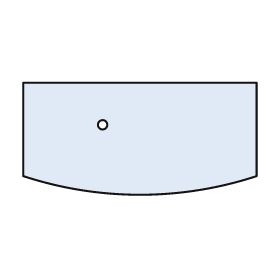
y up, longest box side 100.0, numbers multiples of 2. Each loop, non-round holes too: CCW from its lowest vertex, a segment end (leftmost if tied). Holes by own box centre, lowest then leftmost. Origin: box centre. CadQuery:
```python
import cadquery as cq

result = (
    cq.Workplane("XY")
    .moveTo(-50.0, -16.0)
    .threePointArc((0.0, -24.0), (50.0, -16.0))
    .lineTo(50.0, 24.0)
    .lineTo(-50.0, 24.0)
    .close()
    .moveTo(-16.0, 6.0)
    .circle(2.0)
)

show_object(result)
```